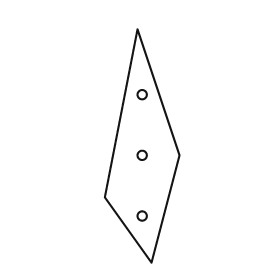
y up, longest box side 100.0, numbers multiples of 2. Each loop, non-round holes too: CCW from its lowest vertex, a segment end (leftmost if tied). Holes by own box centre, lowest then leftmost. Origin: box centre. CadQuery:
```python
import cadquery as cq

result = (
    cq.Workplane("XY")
    .moveTo(4.0, -50.0)
    .lineTo(16.0, -4.0)
    .lineTo(-2.0, 50.0)
    .lineTo(-16.0, -22.0)
    .close()
    .moveTo(0.0, -30.0)
    .circle(2.0)
    .moveTo(0.0, -4.0)
    .circle(2.0)
    .moveTo(0.0, 22.0)
    .circle(2.0)
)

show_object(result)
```